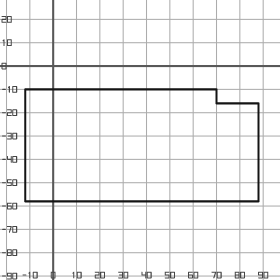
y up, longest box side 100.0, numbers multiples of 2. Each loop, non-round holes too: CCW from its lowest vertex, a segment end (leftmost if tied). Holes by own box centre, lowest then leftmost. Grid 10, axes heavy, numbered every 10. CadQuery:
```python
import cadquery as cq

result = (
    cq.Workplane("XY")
    .moveTo(-12.0, -58.0)
    .lineTo(88.0, -58.0)
    .lineTo(88.0, -16.0)
    .lineTo(70.0, -16.0)
    .lineTo(70.0, -10.0)
    .lineTo(-12.0, -10.0)
    .close()
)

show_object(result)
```